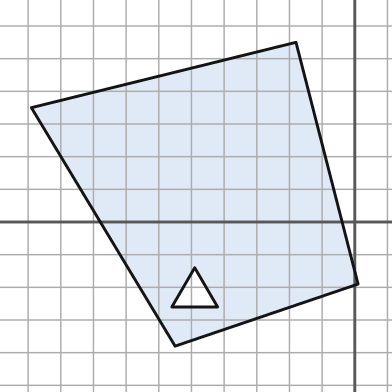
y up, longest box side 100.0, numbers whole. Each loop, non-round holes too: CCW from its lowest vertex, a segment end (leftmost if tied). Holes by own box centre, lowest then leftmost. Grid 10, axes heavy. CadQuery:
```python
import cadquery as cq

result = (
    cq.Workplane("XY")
    .moveTo(-55.0, -38.0)
    .lineTo(1.0, -19.0)
    .lineTo(-18.0, 55.0)
    .lineTo(-99.0, 35.0)
    .close()
    .moveTo(-56.0, -26.0)
    .lineTo(-42.0, -26.0)
    .lineTo(-49.0, -14.0)
    .close()
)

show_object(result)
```